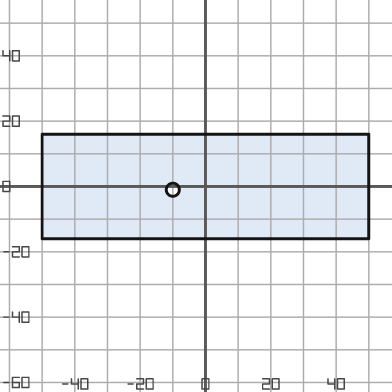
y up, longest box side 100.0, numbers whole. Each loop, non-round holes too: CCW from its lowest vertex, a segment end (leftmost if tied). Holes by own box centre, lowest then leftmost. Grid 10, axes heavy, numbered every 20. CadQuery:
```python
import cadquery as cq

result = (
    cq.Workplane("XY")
    .moveTo(-50.0, -16.0)
    .lineTo(50.0, -16.0)
    .lineTo(50.0, 16.0)
    .lineTo(-50.0, 16.0)
    .close()
    .moveTo(-10.0, -1.0)
    .circle(2.0)
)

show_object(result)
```